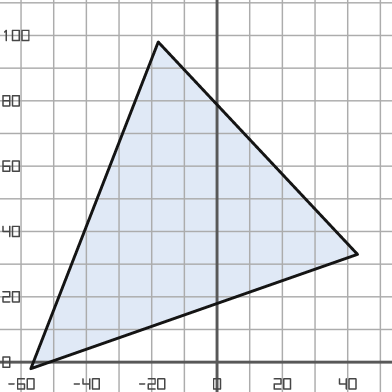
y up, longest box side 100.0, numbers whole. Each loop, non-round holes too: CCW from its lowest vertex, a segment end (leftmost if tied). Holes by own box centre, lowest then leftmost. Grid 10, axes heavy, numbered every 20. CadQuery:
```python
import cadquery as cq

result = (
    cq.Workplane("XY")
    .moveTo(-57.0, -2.0)
    .lineTo(43.0, 33.0)
    .lineTo(-18.0, 98.0)
    .close()
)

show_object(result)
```